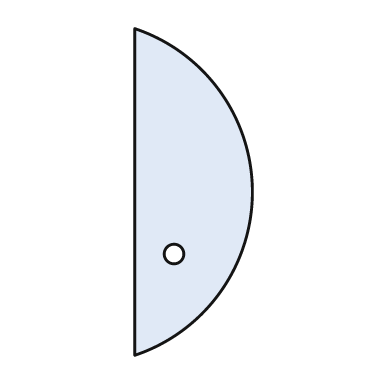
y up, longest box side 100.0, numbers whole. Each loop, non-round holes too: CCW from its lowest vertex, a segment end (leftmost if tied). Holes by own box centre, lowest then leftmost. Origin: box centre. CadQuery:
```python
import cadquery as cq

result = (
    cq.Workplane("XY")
    .moveTo(-18.0, -50.0)
    .threePointArc((18.0, 0.0), (-18.0, 50.0))
    .close()
    .moveTo(-6.0, -19.0)
    .circle(3.0)
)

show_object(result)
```